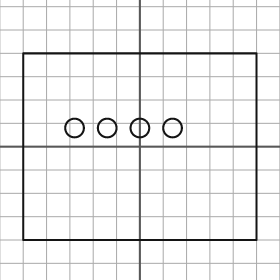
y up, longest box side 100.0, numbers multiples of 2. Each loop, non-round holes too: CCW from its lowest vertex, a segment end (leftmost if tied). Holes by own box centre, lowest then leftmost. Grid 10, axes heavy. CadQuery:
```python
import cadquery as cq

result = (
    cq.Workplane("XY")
    .moveTo(-50.0, -40.0)
    .lineTo(50.0, -40.0)
    .lineTo(50.0, 40.0)
    .lineTo(-50.0, 40.0)
    .close()
    .moveTo(-28.0, 8.0)
    .circle(4.0)
    .moveTo(-14.0, 8.0)
    .circle(4.0)
    .moveTo(0.0, 8.0)
    .circle(4.0)
    .moveTo(14.0, 8.0)
    .circle(4.0)
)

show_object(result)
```